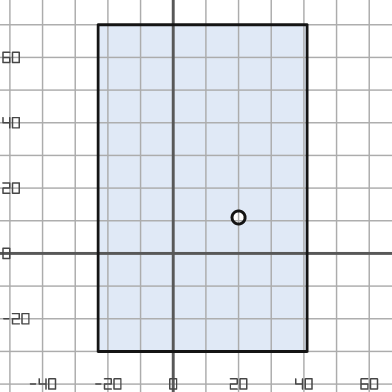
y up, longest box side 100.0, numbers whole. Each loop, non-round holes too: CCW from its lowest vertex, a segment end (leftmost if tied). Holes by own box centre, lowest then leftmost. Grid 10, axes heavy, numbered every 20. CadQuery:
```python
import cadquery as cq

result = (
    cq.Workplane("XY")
    .moveTo(-23.0, -30.0)
    .lineTo(41.0, -30.0)
    .lineTo(41.0, 70.0)
    .lineTo(-23.0, 70.0)
    .close()
    .moveTo(20.0, 11.0)
    .circle(2.0)
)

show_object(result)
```